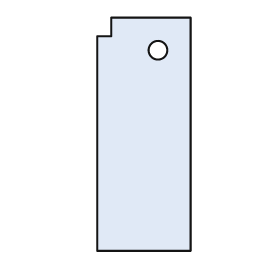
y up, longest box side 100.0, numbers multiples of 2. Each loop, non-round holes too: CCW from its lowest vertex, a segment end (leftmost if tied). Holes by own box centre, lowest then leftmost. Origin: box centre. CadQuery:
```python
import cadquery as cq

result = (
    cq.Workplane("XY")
    .moveTo(-20.0, -50.0)
    .lineTo(20.0, -50.0)
    .lineTo(20.0, 50.0)
    .lineTo(-14.0, 50.0)
    .lineTo(-14.0, 42.0)
    .lineTo(-20.0, 42.0)
    .close()
    .moveTo(6.0, 36.0)
    .circle(4.0)
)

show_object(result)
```